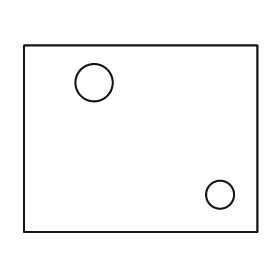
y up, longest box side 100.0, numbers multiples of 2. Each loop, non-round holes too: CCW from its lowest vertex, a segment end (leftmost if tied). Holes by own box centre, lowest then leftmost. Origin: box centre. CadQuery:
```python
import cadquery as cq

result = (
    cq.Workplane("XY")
    .moveTo(-50.0, -40.0)
    .lineTo(50.0, -40.0)
    .lineTo(50.0, 40.0)
    .lineTo(-50.0, 40.0)
    .close()
    .moveTo(34.0, -24.0)
    .circle(6.0)
    .moveTo(-20.0, 24.0)
    .circle(8.0)
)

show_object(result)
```